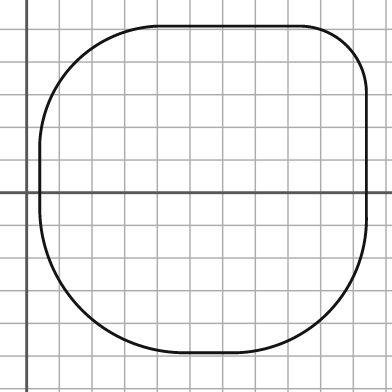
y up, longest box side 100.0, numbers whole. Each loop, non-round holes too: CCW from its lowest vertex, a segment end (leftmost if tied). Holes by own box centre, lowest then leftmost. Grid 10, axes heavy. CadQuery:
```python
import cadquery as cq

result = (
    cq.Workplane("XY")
    .moveTo(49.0, -49.0)
    .lineTo(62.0, -49.0)
    .threePointArc((92.0, -37.0), (104.0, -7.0))
    .lineTo(104.0, 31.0)
    .threePointArc((98.0, 45.0), (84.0, 51.0))
    .lineTo(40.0, 51.0)
    .threePointArc((15.0, 40.0), (4.0, 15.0))
    .lineTo(4.0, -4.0)
    .threePointArc((17.0, -36.0), (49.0, -49.0))
    .close()
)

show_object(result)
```